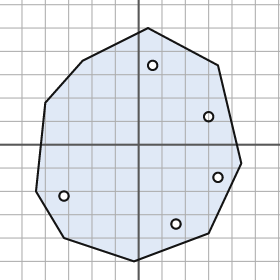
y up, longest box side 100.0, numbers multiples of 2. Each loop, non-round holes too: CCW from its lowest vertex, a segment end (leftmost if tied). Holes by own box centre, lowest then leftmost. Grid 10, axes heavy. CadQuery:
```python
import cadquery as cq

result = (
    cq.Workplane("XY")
    .moveTo(-2.0, -50.0)
    .lineTo(30.0, -38.0)
    .lineTo(44.0, -8.0)
    .lineTo(34.0, 34.0)
    .lineTo(4.0, 50.0)
    .lineTo(-24.0, 36.0)
    .lineTo(-40.0, 18.0)
    .lineTo(-44.0, -20.0)
    .lineTo(-32.0, -40.0)
    .close()
    .moveTo(16.0, -34.0)
    .circle(2.0)
    .moveTo(-32.0, -22.0)
    .circle(2.0)
    .moveTo(34.0, -14.0)
    .circle(2.0)
    .moveTo(30.0, 12.0)
    .circle(2.0)
    .moveTo(6.0, 34.0)
    .circle(2.0)
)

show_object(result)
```